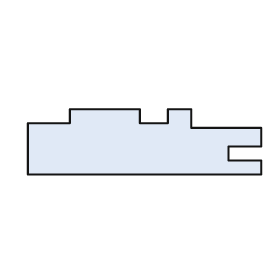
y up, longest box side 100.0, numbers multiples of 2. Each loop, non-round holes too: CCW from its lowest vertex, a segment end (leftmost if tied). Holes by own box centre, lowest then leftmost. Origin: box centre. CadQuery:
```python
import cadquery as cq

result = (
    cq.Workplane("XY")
    .moveTo(-50.0, -14.0)
    .lineTo(50.0, -14.0)
    .lineTo(50.0, -8.0)
    .lineTo(36.0, -8.0)
    .lineTo(36.0, -2.0)
    .lineTo(50.0, -2.0)
    .lineTo(50.0, 6.0)
    .lineTo(20.0, 6.0)
    .lineTo(20.0, 14.0)
    .lineTo(10.0, 14.0)
    .lineTo(10.0, 8.0)
    .lineTo(-2.0, 8.0)
    .lineTo(-2.0, 14.0)
    .lineTo(-32.0, 14.0)
    .lineTo(-32.0, 8.0)
    .lineTo(-50.0, 8.0)
    .close()
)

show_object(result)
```